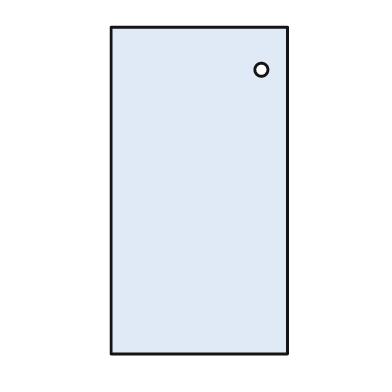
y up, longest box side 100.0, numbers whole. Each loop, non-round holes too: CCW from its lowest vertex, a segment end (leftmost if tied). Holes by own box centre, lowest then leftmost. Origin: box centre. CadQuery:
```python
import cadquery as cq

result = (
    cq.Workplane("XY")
    .moveTo(-27.0, -50.0)
    .lineTo(27.0, -50.0)
    .lineTo(27.0, 50.0)
    .lineTo(-27.0, 50.0)
    .close()
    .moveTo(19.0, 37.0)
    .circle(2.0)
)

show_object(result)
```